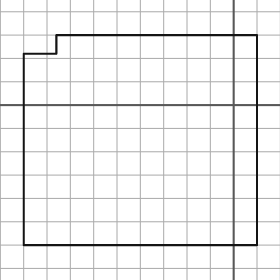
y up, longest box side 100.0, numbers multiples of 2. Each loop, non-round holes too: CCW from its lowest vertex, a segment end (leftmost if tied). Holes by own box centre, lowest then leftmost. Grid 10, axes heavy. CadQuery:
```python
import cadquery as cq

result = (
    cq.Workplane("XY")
    .moveTo(-90.0, -60.0)
    .lineTo(10.0, -60.0)
    .lineTo(10.0, 30.0)
    .lineTo(-76.0, 30.0)
    .lineTo(-76.0, 22.0)
    .lineTo(-90.0, 22.0)
    .close()
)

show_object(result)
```